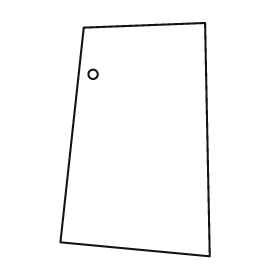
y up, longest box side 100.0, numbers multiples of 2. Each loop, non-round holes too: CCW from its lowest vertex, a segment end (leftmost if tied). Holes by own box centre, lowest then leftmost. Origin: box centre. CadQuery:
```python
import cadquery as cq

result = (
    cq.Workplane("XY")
    .moveTo(32.0, -50.0)
    .lineTo(30.0, 50.0)
    .lineTo(-22.0, 48.0)
    .lineTo(-32.0, -44.0)
    .close()
    .moveTo(-18.0, 28.0)
    .circle(2.0)
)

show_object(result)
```